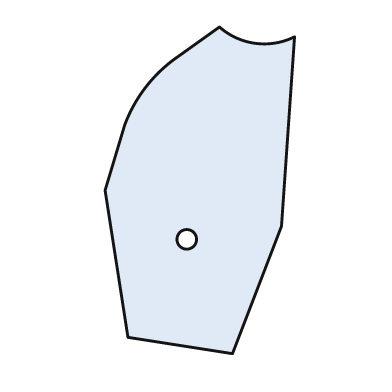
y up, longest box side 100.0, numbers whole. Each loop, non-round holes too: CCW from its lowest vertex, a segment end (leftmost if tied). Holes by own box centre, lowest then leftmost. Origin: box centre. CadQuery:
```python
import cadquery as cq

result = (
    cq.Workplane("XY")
    .moveTo(10.0, -50.0)
    .lineTo(25.0, -11.0)
    .lineTo(29.0, 47.0)
    .threePointArc((17.0, 45.0), (6.0, 50.0))
    .lineTo(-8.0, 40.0)
    .threePointArc((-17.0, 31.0), (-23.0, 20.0))
    .lineTo(-29.0, 0.0)
    .lineTo(-22.0, -45.0)
    .close()
    .moveTo(-4.0, -15.0)
    .circle(3.0)
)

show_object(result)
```